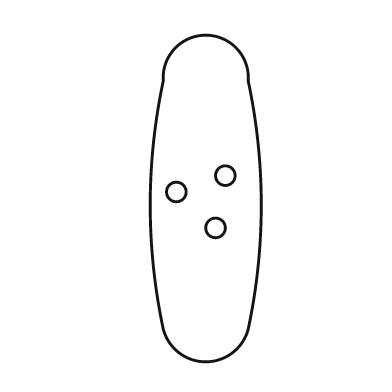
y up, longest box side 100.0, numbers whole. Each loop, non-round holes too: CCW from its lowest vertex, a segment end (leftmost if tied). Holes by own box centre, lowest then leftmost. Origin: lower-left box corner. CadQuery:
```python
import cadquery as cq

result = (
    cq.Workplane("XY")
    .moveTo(4.0, 10.0)
    .threePointArc((17.0, 0.0), (30.0, 10.0))
    .threePointArc((34.0, 48.0), (30.0, 86.0))
    .threePointArc((17.0, 100.0), (4.0, 86.0))
    .threePointArc((0.0, 48.0), (4.0, 10.0))
    .close()
    .moveTo(20.0, 41.0)
    .circle(3.0)
    .moveTo(8.0, 52.0)
    .circle(3.0)
    .moveTo(23.0, 57.0)
    .circle(3.0)
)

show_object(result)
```